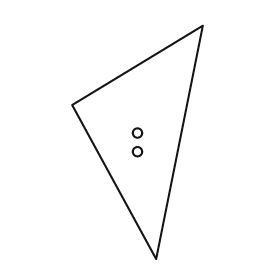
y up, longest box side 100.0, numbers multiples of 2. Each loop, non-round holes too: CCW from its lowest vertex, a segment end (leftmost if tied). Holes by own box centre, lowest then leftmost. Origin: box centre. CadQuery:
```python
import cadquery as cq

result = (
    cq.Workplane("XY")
    .moveTo(8.0, -50.0)
    .lineTo(28.0, 50.0)
    .lineTo(-28.0, 16.0)
    .close()
    .moveTo(0.0, -4.0)
    .circle(2.0)
    .moveTo(0.0, 4.0)
    .circle(2.0)
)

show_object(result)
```